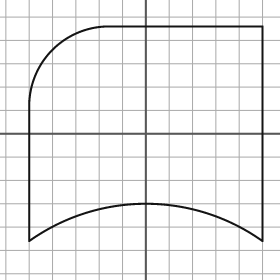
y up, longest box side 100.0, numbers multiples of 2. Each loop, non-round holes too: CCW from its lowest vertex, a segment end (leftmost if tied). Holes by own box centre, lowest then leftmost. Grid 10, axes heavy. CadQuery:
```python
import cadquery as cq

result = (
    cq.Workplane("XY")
    .moveTo(-50.0, -46.0)
    .threePointArc((0.0, -30.0), (50.0, -46.0))
    .lineTo(50.0, 46.0)
    .lineTo(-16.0, 46.0)
    .threePointArc((-40.0, 36.0), (-50.0, 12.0))
    .close()
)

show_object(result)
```